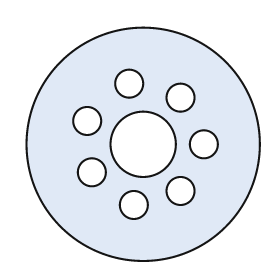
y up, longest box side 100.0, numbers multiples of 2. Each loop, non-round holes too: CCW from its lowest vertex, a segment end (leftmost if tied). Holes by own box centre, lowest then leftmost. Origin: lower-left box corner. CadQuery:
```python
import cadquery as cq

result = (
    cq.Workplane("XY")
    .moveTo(50.0, 50.0)
    .circle(50.0)
    .moveTo(46.0, 24.0)
    .circle(6.0)
    .moveTo(66.0, 30.0)
    .circle(6.0)
    .moveTo(28.0, 38.0)
    .circle(6.0)
    .moveTo(50.0, 50.0)
    .circle(14.0)
    .moveTo(76.0, 50.0)
    .circle(6.0)
    .moveTo(26.0, 60.0)
    .circle(6.0)
    .moveTo(66.0, 70.0)
    .circle(6.0)
    .moveTo(44.0, 76.0)
    .circle(6.0)
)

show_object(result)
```